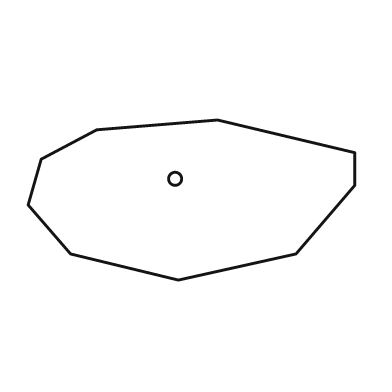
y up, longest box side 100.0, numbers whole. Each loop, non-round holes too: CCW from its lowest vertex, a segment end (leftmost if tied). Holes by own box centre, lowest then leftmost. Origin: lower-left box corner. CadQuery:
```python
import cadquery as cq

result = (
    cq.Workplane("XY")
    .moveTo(46.0, 0.0)
    .lineTo(82.0, 8.0)
    .lineTo(100.0, 29.0)
    .lineTo(100.0, 39.0)
    .lineTo(58.0, 49.0)
    .lineTo(21.0, 46.0)
    .lineTo(4.0, 37.0)
    .lineTo(0.0, 23.0)
    .lineTo(13.0, 8.0)
    .close()
    .moveTo(45.0, 31.0)
    .circle(2.0)
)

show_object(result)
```